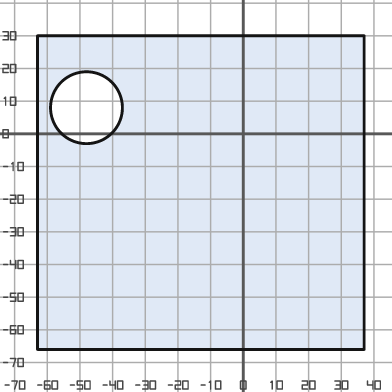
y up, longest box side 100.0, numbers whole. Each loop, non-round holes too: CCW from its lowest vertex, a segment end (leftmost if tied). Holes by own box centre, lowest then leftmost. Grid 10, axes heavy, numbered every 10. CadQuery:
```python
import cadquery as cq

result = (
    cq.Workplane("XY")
    .moveTo(-63.0, -66.0)
    .lineTo(37.0, -66.0)
    .lineTo(37.0, 30.0)
    .lineTo(-63.0, 30.0)
    .close()
    .moveTo(-48.0, 8.0)
    .circle(11.0)
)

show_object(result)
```